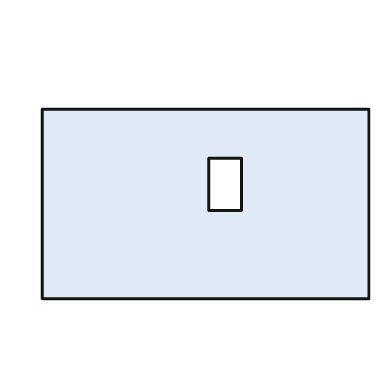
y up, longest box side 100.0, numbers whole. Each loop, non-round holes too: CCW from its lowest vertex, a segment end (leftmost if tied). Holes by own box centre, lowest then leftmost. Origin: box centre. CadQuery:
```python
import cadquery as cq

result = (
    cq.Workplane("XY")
    .moveTo(-50.0, -29.0)
    .lineTo(50.0, -29.0)
    .lineTo(50.0, 29.0)
    .lineTo(-50.0, 29.0)
    .close()
    .moveTo(1.0, -2.0)
    .lineTo(11.0, -2.0)
    .lineTo(11.0, 14.0)
    .lineTo(1.0, 14.0)
    .close()
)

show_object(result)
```